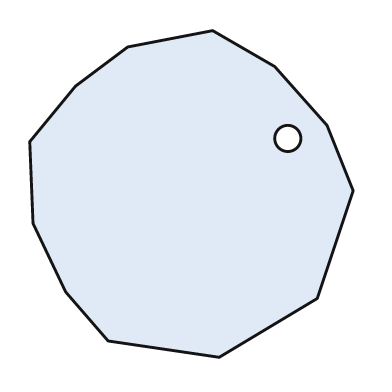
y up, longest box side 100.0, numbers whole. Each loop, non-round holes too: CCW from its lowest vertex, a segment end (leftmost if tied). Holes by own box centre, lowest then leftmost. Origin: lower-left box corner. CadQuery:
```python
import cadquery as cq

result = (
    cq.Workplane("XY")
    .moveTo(58.0, 0.0)
    .lineTo(88.0, 18.0)
    .lineTo(99.0, 51.0)
    .lineTo(91.0, 71.0)
    .lineTo(75.0, 89.0)
    .lineTo(56.0, 100.0)
    .lineTo(30.0, 95.0)
    .lineTo(14.0, 83.0)
    .lineTo(0.0, 66.0)
    .lineTo(1.0, 41.0)
    .lineTo(11.0, 20.0)
    .lineTo(24.0, 5.0)
    .close()
    .moveTo(79.0, 67.0)
    .circle(4.0)
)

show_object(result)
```